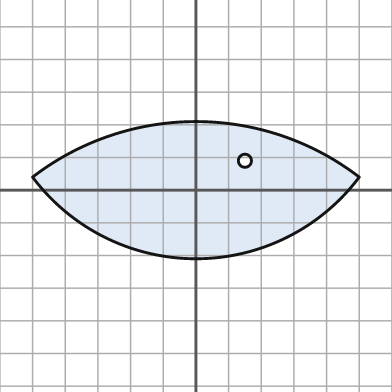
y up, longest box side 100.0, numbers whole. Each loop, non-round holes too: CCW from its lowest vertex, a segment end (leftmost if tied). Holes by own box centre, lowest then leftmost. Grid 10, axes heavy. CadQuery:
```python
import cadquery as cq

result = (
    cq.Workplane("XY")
    .moveTo(-50.0, 4.0)
    .threePointArc((0.0, -21.0), (50.0, 4.0))
    .threePointArc((0.0, 21.0), (-50.0, 4.0))
    .close()
    .moveTo(15.0, 9.0)
    .circle(2.0)
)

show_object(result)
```